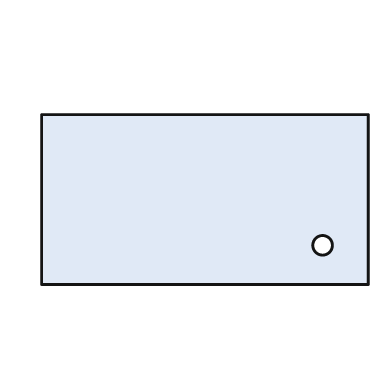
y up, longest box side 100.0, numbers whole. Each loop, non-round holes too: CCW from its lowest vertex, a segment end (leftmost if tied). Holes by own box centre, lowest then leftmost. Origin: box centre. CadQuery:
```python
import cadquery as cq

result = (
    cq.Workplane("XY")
    .moveTo(-50.0, -26.0)
    .lineTo(50.0, -26.0)
    .lineTo(50.0, 26.0)
    .lineTo(-50.0, 26.0)
    .close()
    .moveTo(36.0, -14.0)
    .circle(3.0)
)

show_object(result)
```